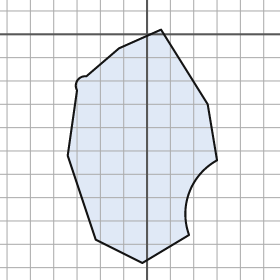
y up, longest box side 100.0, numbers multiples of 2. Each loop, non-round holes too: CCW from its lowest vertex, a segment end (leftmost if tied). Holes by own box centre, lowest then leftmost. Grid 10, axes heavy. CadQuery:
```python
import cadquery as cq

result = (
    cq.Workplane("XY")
    .moveTo(-2.0, -98.0)
    .lineTo(18.0, -86.0)
    .threePointArc((18.0, -68.0), (30.0, -54.0))
    .lineTo(26.0, -30.0)
    .lineTo(6.0, 2.0)
    .lineTo(-12.0, -6.0)
    .lineTo(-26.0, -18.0)
    .threePointArc((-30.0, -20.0), (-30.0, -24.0))
    .lineTo(-34.0, -52.0)
    .lineTo(-22.0, -88.0)
    .close()
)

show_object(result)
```